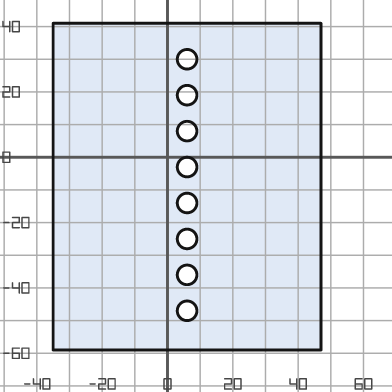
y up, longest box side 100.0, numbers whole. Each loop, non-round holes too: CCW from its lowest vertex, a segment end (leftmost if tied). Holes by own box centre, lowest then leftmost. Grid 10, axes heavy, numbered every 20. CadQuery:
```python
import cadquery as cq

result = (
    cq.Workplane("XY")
    .moveTo(-35.0, -59.0)
    .lineTo(47.0, -59.0)
    .lineTo(47.0, 41.0)
    .lineTo(-35.0, 41.0)
    .close()
    .moveTo(6.0, -47.0)
    .circle(3.0)
    .moveTo(6.0, -36.0)
    .circle(3.0)
    .moveTo(6.0, -25.0)
    .circle(3.0)
    .moveTo(6.0, -14.0)
    .circle(3.0)
    .moveTo(6.0, -3.0)
    .circle(3.0)
    .moveTo(6.0, 8.0)
    .circle(3.0)
    .moveTo(6.0, 19.0)
    .circle(3.0)
    .moveTo(6.0, 30.0)
    .circle(3.0)
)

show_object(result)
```